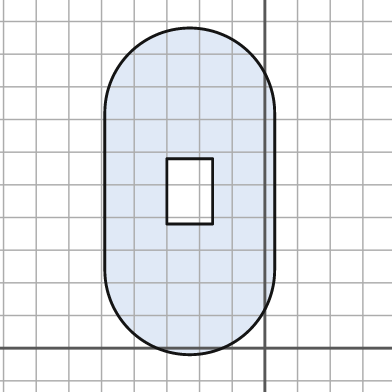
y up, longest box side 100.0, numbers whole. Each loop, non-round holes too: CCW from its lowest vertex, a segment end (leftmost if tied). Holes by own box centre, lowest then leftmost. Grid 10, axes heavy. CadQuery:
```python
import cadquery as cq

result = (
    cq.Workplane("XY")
    .moveTo(-49.0, 24.0)
    .threePointArc((-23.0, -2.0), (3.0, 24.0))
    .lineTo(3.0, 72.0)
    .threePointArc((-23.0, 98.0), (-49.0, 72.0))
    .close()
    .moveTo(-30.0, 38.0)
    .lineTo(-16.0, 38.0)
    .lineTo(-16.0, 58.0)
    .lineTo(-30.0, 58.0)
    .close()
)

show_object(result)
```